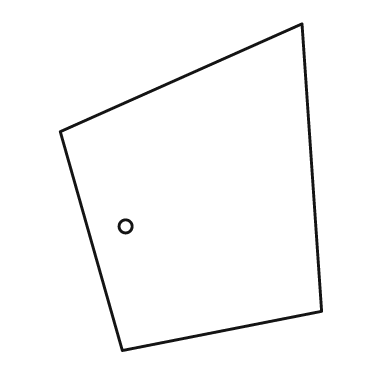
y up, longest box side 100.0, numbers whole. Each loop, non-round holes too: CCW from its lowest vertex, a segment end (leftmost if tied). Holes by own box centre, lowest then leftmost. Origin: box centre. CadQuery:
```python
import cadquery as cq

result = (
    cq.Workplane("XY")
    .moveTo(-21.0, -50.0)
    .lineTo(40.0, -38.0)
    .lineTo(34.0, 50.0)
    .lineTo(-40.0, 17.0)
    .close()
    .moveTo(-20.0, -12.0)
    .circle(2.0)
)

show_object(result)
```